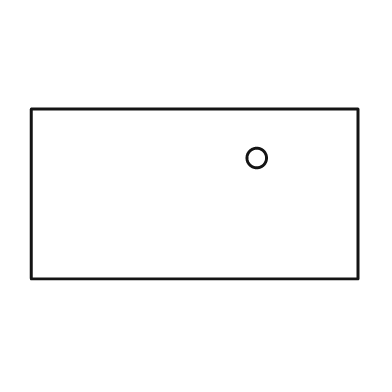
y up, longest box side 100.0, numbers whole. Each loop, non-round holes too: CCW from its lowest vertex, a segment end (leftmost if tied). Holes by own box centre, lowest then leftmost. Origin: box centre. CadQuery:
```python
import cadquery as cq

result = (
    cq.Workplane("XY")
    .moveTo(-50.0, -26.0)
    .lineTo(50.0, -26.0)
    .lineTo(50.0, 26.0)
    .lineTo(-50.0, 26.0)
    .close()
    .moveTo(19.0, 11.0)
    .circle(3.0)
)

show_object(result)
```